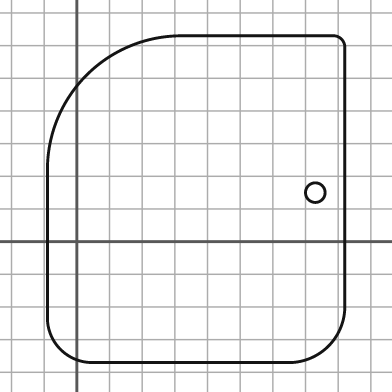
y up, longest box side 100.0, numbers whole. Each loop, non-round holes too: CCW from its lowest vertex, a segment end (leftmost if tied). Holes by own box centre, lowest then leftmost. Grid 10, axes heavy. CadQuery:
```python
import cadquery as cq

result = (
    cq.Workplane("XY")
    .moveTo(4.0, -37.0)
    .lineTo(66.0, -37.0)
    .threePointArc((77.0, -32.0), (82.0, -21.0))
    .lineTo(82.0, 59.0)
    .threePointArc((81.0, 62.0), (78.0, 63.0))
    .lineTo(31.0, 63.0)
    .threePointArc((3.0, 51.0), (-9.0, 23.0))
    .lineTo(-9.0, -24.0)
    .threePointArc((-5.0, -33.0), (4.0, -37.0))
    .close()
    .moveTo(73.0, 15.0)
    .circle(3.0)
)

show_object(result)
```